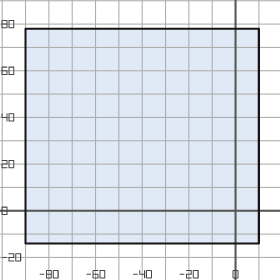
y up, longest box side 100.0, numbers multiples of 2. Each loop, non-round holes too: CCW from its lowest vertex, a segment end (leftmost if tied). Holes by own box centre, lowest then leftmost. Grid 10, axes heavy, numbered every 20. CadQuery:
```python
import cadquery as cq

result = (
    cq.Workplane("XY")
    .moveTo(-90.0, -14.0)
    .lineTo(10.0, -14.0)
    .lineTo(10.0, 78.0)
    .lineTo(-90.0, 78.0)
    .close()
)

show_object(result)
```